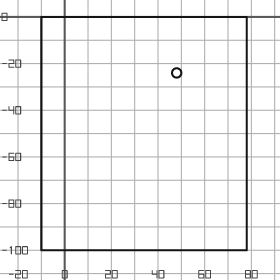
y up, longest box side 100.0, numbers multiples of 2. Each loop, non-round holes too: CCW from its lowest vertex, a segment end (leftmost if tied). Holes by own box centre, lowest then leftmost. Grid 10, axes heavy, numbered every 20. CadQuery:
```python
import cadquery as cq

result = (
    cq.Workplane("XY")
    .moveTo(-10.0, -100.0)
    .lineTo(78.0, -100.0)
    .lineTo(78.0, 0.0)
    .lineTo(-10.0, 0.0)
    .close()
    .moveTo(48.0, -24.0)
    .circle(2.0)
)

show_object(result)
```